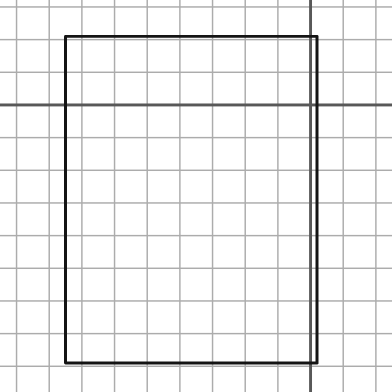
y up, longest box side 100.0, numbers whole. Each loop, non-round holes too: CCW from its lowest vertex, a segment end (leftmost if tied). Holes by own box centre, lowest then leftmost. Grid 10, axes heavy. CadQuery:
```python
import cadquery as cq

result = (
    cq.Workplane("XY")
    .moveTo(-75.0, -79.0)
    .lineTo(2.0, -79.0)
    .lineTo(2.0, 21.0)
    .lineTo(-75.0, 21.0)
    .close()
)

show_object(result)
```